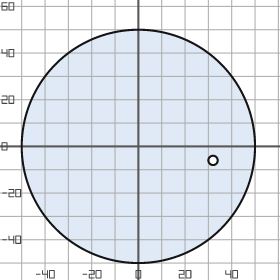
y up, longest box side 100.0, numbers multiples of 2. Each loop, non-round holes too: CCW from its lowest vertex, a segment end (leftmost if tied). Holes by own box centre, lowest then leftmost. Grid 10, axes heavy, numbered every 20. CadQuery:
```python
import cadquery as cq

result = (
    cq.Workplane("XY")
    .moveTo(0.0, 0.0)
    .circle(50.0)
    .moveTo(32.0, -6.0)
    .circle(2.0)
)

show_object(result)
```